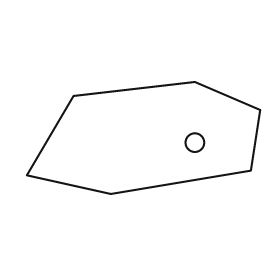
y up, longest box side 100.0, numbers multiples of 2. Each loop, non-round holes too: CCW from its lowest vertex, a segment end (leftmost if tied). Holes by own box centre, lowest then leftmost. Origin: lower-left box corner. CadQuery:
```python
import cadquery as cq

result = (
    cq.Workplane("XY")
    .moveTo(36.0, 0.0)
    .lineTo(96.0, 10.0)
    .lineTo(100.0, 36.0)
    .lineTo(72.0, 48.0)
    .lineTo(20.0, 42.0)
    .lineTo(0.0, 8.0)
    .close()
    .moveTo(72.0, 22.0)
    .circle(4.0)
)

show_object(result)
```